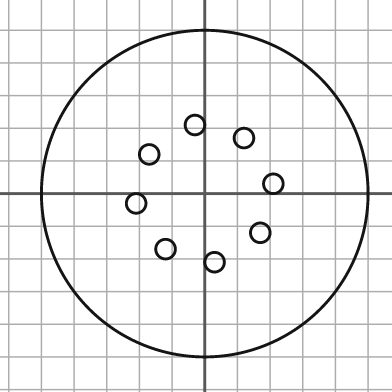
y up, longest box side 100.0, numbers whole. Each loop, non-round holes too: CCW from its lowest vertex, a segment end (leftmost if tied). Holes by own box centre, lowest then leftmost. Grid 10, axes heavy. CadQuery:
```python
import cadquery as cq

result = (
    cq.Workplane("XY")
    .moveTo(0.0, 0.0)
    .circle(50.0)
    .moveTo(3.0, -21.0)
    .circle(3.0)
    .moveTo(-12.0, -17.0)
    .circle(3.0)
    .moveTo(17.0, -12.0)
    .circle(3.0)
    .moveTo(-21.0, -3.0)
    .circle(3.0)
    .moveTo(21.0, 3.0)
    .circle(3.0)
    .moveTo(-17.0, 12.0)
    .circle(3.0)
    .moveTo(12.0, 17.0)
    .circle(3.0)
    .moveTo(-3.0, 21.0)
    .circle(3.0)
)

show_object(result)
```